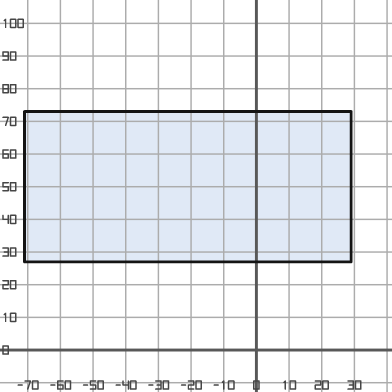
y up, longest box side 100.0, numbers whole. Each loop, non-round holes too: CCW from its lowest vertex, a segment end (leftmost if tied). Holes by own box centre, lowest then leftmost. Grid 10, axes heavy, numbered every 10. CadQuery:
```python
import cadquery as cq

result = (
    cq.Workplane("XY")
    .moveTo(-71.0, 27.0)
    .lineTo(29.0, 27.0)
    .lineTo(29.0, 73.0)
    .lineTo(-71.0, 73.0)
    .close()
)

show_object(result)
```